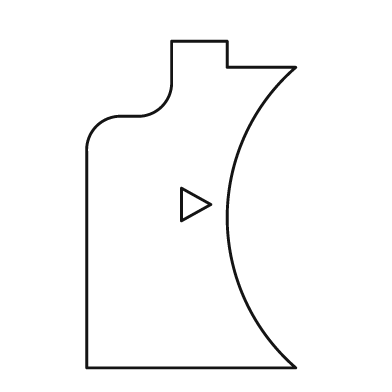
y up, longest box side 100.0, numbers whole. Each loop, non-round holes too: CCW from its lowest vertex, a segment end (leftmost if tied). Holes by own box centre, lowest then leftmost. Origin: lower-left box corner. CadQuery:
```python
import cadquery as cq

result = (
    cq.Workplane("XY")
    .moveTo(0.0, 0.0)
    .lineTo(64.0, 0.0)
    .threePointArc((43.0, 46.0), (64.0, 92.0))
    .lineTo(43.0, 92.0)
    .lineTo(43.0, 100.0)
    .lineTo(26.0, 100.0)
    .lineTo(26.0, 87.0)
    .threePointArc((23.0, 80.0), (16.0, 77.0))
    .lineTo(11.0, 77.0)
    .threePointArc((3.0, 74.0), (0.0, 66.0))
    .close()
    .moveTo(29.0, 45.0)
    .lineTo(38.0, 50.0)
    .lineTo(29.0, 55.0)
    .close()
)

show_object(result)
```